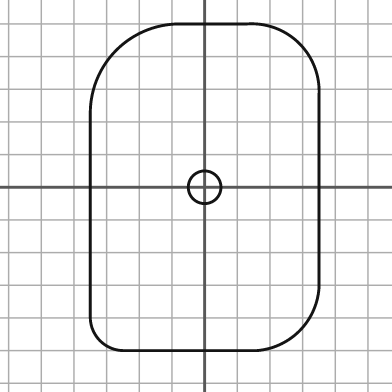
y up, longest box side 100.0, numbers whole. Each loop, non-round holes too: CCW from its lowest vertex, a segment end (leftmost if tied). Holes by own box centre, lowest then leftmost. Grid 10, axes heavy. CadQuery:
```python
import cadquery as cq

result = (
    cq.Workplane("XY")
    .moveTo(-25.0, -50.0)
    .lineTo(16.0, -50.0)
    .threePointArc((29.0, -44.0), (35.0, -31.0))
    .lineTo(35.0, 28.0)
    .threePointArc((29.0, 44.0), (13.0, 50.0))
    .lineTo(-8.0, 50.0)
    .threePointArc((-27.0, 42.0), (-35.0, 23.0))
    .lineTo(-35.0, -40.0)
    .threePointArc((-32.0, -47.0), (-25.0, -50.0))
    .close()
    .moveTo(0.0, 0.0)
    .circle(5.0)
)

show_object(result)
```